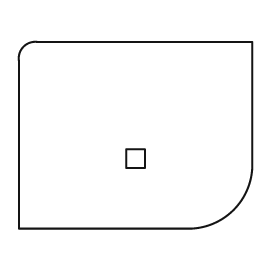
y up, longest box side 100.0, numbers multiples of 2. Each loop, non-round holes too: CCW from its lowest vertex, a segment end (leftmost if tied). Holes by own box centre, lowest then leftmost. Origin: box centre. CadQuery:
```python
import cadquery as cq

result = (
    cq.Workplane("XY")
    .moveTo(-50.0, -40.0)
    .lineTo(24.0, -40.0)
    .threePointArc((42.0, -32.0), (50.0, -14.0))
    .lineTo(50.0, 40.0)
    .lineTo(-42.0, 40.0)
    .threePointArc((-48.0, 38.0), (-50.0, 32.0))
    .close()
    .moveTo(-4.0, -14.0)
    .lineTo(4.0, -14.0)
    .lineTo(4.0, -6.0)
    .lineTo(-4.0, -6.0)
    .close()
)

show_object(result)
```